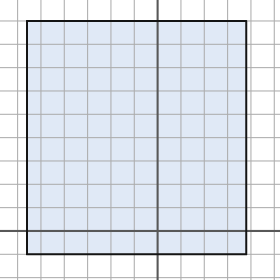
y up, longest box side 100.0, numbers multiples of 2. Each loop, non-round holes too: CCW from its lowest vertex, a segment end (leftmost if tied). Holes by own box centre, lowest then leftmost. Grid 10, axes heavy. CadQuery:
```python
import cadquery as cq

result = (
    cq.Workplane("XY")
    .moveTo(-56.0, -10.0)
    .lineTo(38.0, -10.0)
    .lineTo(38.0, 90.0)
    .lineTo(-56.0, 90.0)
    .close()
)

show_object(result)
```